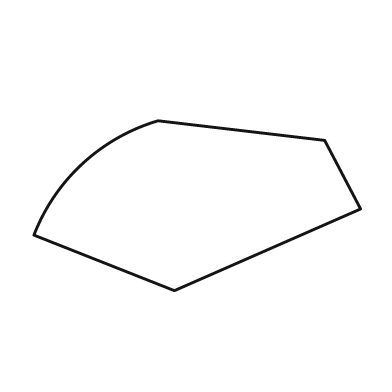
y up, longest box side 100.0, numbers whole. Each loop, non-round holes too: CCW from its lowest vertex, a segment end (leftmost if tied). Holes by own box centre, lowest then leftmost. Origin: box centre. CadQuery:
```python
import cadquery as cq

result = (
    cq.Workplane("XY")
    .moveTo(-7.0, -26.0)
    .lineTo(50.0, -1.0)
    .lineTo(39.0, 20.0)
    .lineTo(-12.0, 26.0)
    .threePointArc((-35.0, 13.0), (-50.0, -9.0))
    .close()
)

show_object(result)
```